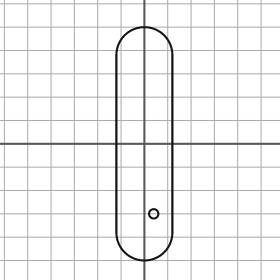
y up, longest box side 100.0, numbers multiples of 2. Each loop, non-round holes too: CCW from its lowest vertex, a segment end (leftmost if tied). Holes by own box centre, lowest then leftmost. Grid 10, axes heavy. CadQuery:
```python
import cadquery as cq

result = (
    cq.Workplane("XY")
    .moveTo(-12.0, -38.0)
    .threePointArc((0.0, -50.0), (12.0, -38.0))
    .lineTo(12.0, 38.0)
    .threePointArc((0.0, 50.0), (-12.0, 38.0))
    .close()
    .moveTo(4.0, -30.0)
    .circle(2.0)
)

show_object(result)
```